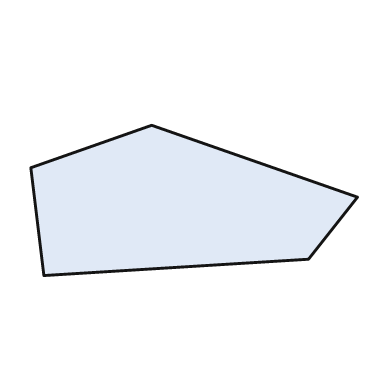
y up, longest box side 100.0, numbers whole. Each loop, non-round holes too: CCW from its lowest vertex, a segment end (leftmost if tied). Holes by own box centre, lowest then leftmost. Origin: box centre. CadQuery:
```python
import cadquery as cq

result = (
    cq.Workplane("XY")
    .moveTo(-46.0, -23.0)
    .lineTo(35.0, -18.0)
    .lineTo(50.0, 1.0)
    .lineTo(-13.0, 23.0)
    .lineTo(-50.0, 10.0)
    .close()
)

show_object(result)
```